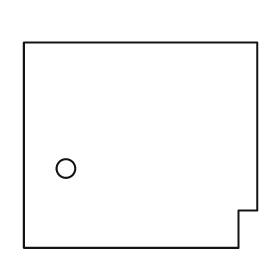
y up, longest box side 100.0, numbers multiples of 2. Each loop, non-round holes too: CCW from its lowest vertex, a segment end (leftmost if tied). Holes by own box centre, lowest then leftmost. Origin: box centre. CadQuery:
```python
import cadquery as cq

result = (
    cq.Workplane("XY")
    .moveTo(-50.0, -44.0)
    .lineTo(42.0, -44.0)
    .lineTo(42.0, -28.0)
    .lineTo(50.0, -28.0)
    .lineTo(50.0, 44.0)
    .lineTo(-50.0, 44.0)
    .close()
    .moveTo(-32.0, -10.0)
    .circle(4.0)
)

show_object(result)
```